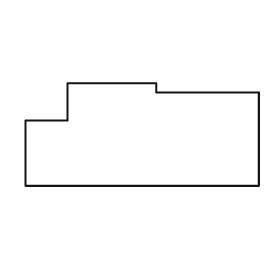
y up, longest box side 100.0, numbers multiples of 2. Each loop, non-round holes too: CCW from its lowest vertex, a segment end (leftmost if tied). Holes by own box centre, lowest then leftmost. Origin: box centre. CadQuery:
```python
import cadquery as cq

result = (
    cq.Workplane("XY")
    .moveTo(-50.0, -22.0)
    .lineTo(50.0, -22.0)
    .lineTo(50.0, 18.0)
    .lineTo(6.0, 18.0)
    .lineTo(6.0, 22.0)
    .lineTo(-32.0, 22.0)
    .lineTo(-32.0, 6.0)
    .lineTo(-50.0, 6.0)
    .close()
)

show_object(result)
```